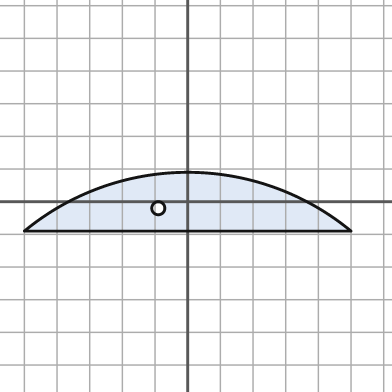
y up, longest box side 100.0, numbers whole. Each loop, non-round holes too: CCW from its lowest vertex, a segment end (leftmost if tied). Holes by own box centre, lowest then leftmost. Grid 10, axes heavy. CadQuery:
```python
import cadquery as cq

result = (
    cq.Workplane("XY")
    .moveTo(-50.0, -9.0)
    .lineTo(50.0, -9.0)
    .threePointArc((0.0, 9.0), (-50.0, -9.0))
    .close()
    .moveTo(-9.0, -2.0)
    .circle(2.0)
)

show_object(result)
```